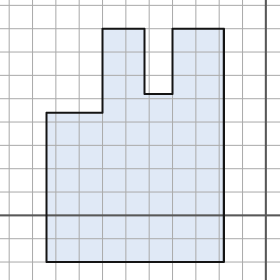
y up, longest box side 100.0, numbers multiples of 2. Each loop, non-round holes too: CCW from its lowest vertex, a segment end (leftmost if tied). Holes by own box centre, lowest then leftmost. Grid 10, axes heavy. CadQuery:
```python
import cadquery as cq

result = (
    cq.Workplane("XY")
    .moveTo(-94.0, -20.0)
    .lineTo(-18.0, -20.0)
    .lineTo(-18.0, 80.0)
    .lineTo(-40.0, 80.0)
    .lineTo(-40.0, 52.0)
    .lineTo(-52.0, 52.0)
    .lineTo(-52.0, 80.0)
    .lineTo(-70.0, 80.0)
    .lineTo(-70.0, 44.0)
    .lineTo(-94.0, 44.0)
    .close()
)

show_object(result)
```